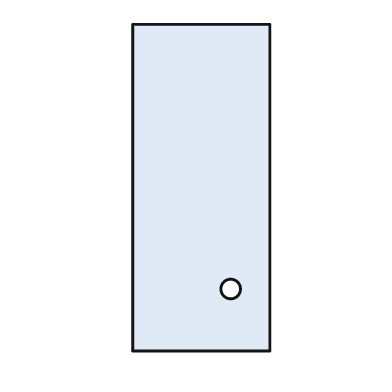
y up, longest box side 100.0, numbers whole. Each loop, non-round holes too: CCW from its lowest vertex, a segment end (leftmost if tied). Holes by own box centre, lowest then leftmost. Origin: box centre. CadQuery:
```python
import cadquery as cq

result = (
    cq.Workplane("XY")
    .moveTo(-21.0, -50.0)
    .lineTo(21.0, -50.0)
    .lineTo(21.0, 50.0)
    .lineTo(-21.0, 50.0)
    .close()
    .moveTo(9.0, -31.0)
    .circle(3.0)
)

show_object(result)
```